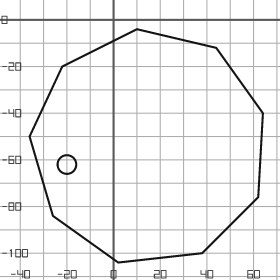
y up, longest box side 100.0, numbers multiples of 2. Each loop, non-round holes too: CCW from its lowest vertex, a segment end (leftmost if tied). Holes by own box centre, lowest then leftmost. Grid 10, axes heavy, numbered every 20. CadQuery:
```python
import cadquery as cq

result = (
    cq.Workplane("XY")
    .moveTo(2.0, -104.0)
    .lineTo(38.0, -100.0)
    .lineTo(62.0, -76.0)
    .lineTo(64.0, -40.0)
    .lineTo(44.0, -12.0)
    .lineTo(10.0, -4.0)
    .lineTo(-22.0, -20.0)
    .lineTo(-36.0, -50.0)
    .lineTo(-26.0, -84.0)
    .close()
    .moveTo(-20.0, -62.0)
    .circle(4.0)
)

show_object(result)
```